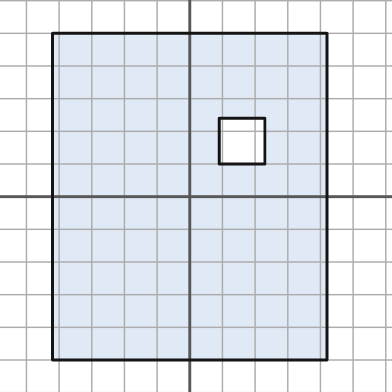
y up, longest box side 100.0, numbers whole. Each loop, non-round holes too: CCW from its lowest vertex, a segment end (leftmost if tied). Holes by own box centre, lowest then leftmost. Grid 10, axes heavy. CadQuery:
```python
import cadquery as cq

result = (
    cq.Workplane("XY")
    .moveTo(-42.0, -50.0)
    .lineTo(42.0, -50.0)
    .lineTo(42.0, 50.0)
    .lineTo(-42.0, 50.0)
    .close()
    .moveTo(9.0, 10.0)
    .lineTo(23.0, 10.0)
    .lineTo(23.0, 24.0)
    .lineTo(9.0, 24.0)
    .close()
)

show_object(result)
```